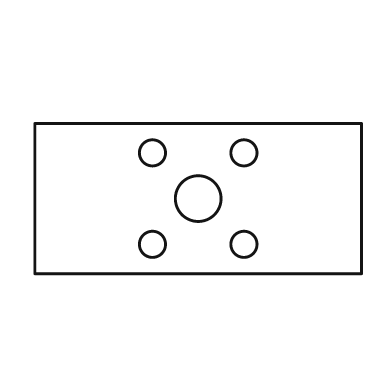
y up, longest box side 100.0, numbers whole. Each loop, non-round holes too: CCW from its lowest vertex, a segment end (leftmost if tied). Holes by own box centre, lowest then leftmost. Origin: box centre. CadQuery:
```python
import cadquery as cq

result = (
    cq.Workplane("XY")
    .moveTo(-50.0, -23.0)
    .lineTo(50.0, -23.0)
    .lineTo(50.0, 23.0)
    .lineTo(-50.0, 23.0)
    .close()
    .moveTo(-14.0, -14.0)
    .circle(4.0)
    .moveTo(14.0, -14.0)
    .circle(4.0)
    .moveTo(0.0, 0.0)
    .circle(7.0)
    .moveTo(-14.0, 14.0)
    .circle(4.0)
    .moveTo(14.0, 14.0)
    .circle(4.0)
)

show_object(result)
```